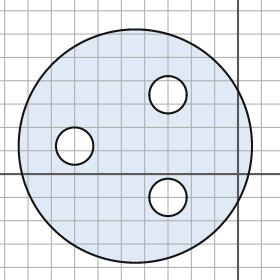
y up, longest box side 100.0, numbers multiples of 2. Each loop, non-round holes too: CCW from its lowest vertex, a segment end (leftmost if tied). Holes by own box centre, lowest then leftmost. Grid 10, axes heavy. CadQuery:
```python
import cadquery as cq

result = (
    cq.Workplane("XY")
    .moveTo(-44.0, 12.0)
    .circle(50.0)
    .moveTo(-30.0, -10.0)
    .circle(8.0)
    .moveTo(-70.0, 12.0)
    .circle(8.0)
    .moveTo(-30.0, 34.0)
    .circle(8.0)
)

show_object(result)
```